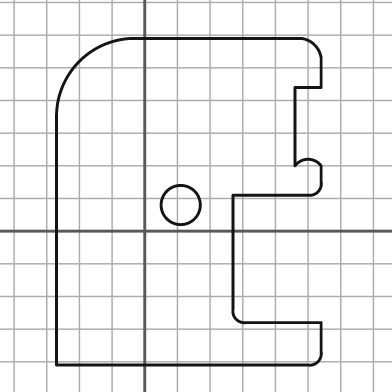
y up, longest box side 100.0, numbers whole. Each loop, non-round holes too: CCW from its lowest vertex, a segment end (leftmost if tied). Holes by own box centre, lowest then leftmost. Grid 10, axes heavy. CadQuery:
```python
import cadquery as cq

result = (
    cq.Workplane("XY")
    .moveTo(-27.0, -41.0)
    .lineTo(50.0, -41.0)
    .threePointArc((53.0, -40.0), (54.0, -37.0))
    .lineTo(54.0, -28.0)
    .lineTo(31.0, -28.0)
    .threePointArc((28.0, -27.0), (27.0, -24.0))
    .lineTo(27.0, 11.0)
    .lineTo(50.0, 11.0)
    .threePointArc((53.0, 12.0), (54.0, 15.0))
    .lineTo(54.0, 20.0)
    .threePointArc((50.0, 22.0), (46.0, 20.0))
    .lineTo(46.0, 44.0)
    .lineTo(54.0, 44.0)
    .lineTo(54.0, 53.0)
    .threePointArc((52.0, 57.0), (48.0, 59.0))
    .lineTo(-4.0, 59.0)
    .threePointArc((-20.0, 52.0), (-27.0, 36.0))
    .close()
    .moveTo(11.0, 8.0)
    .circle(6.0)
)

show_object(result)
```